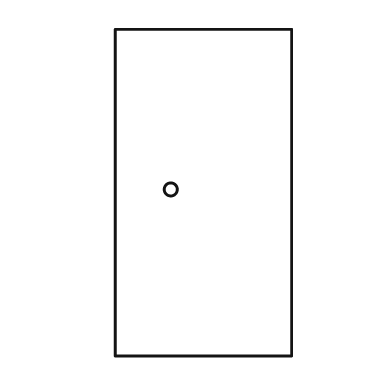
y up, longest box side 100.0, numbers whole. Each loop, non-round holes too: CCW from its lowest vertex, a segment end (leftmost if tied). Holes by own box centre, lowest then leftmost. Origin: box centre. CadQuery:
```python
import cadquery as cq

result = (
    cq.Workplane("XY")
    .moveTo(-27.0, -50.0)
    .lineTo(27.0, -50.0)
    .lineTo(27.0, 50.0)
    .lineTo(-27.0, 50.0)
    .close()
    .moveTo(-10.0, 1.0)
    .circle(2.0)
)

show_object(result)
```